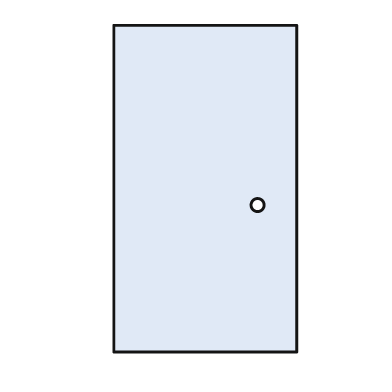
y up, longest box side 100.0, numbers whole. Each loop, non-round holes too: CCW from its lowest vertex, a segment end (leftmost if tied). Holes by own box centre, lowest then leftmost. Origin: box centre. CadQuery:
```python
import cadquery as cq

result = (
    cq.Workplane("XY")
    .moveTo(-28.0, -50.0)
    .lineTo(28.0, -50.0)
    .lineTo(28.0, 50.0)
    .lineTo(-28.0, 50.0)
    .close()
    .moveTo(16.0, -5.0)
    .circle(2.0)
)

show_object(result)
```